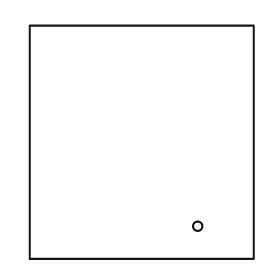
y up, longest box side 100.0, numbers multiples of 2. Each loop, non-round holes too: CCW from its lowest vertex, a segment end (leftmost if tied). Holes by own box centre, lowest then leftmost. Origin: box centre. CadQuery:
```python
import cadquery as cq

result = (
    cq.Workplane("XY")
    .moveTo(-48.0, -50.0)
    .lineTo(48.0, -50.0)
    .lineTo(48.0, 50.0)
    .lineTo(-48.0, 50.0)
    .close()
    .moveTo(24.0, -36.0)
    .circle(2.0)
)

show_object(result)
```